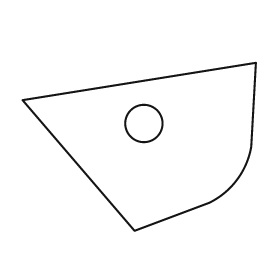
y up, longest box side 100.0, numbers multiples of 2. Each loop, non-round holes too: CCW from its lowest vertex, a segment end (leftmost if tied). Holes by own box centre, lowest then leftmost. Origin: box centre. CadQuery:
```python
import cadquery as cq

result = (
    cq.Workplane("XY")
    .moveTo(-2.0, -36.0)
    .lineTo(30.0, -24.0)
    .threePointArc((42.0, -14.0), (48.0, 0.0))
    .lineTo(50.0, 36.0)
    .lineTo(-50.0, 20.0)
    .close()
    .moveTo(2.0, 10.0)
    .circle(8.0)
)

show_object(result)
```